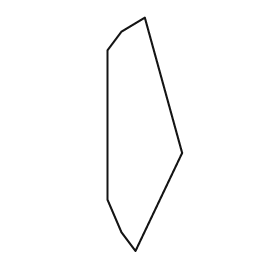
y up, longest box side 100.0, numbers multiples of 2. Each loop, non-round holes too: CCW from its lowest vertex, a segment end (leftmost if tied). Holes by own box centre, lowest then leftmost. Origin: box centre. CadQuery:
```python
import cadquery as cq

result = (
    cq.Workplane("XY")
    .moveTo(-4.0, -50.0)
    .lineTo(16.0, -8.0)
    .lineTo(0.0, 50.0)
    .lineTo(-10.0, 44.0)
    .lineTo(-16.0, 36.0)
    .lineTo(-16.0, -28.0)
    .lineTo(-10.0, -42.0)
    .close()
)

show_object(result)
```